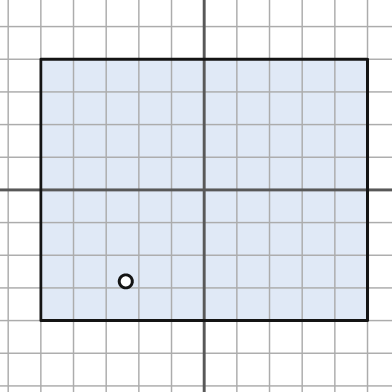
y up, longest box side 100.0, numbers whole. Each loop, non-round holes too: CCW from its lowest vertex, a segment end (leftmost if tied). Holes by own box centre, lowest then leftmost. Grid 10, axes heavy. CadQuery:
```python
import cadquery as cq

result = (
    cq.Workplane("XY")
    .moveTo(-50.0, -40.0)
    .lineTo(50.0, -40.0)
    .lineTo(50.0, 40.0)
    .lineTo(-50.0, 40.0)
    .close()
    .moveTo(-24.0, -28.0)
    .circle(2.0)
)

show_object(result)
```